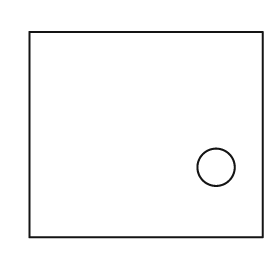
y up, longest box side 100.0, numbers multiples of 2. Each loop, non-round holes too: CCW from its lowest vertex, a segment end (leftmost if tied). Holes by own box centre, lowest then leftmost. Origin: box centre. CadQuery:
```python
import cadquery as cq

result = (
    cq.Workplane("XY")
    .moveTo(-50.0, -44.0)
    .lineTo(50.0, -44.0)
    .lineTo(50.0, 44.0)
    .lineTo(-50.0, 44.0)
    .close()
    .moveTo(30.0, -14.0)
    .circle(8.0)
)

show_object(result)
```